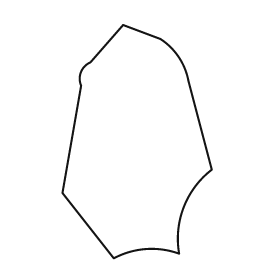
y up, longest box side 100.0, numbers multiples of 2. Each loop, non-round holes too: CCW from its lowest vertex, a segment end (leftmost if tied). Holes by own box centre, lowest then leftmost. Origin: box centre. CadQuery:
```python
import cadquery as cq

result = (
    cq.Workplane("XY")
    .moveTo(-10.0, -50.0)
    .threePointArc((4.0, -46.0), (18.0, -48.0))
    .threePointArc((20.0, -28.0), (32.0, -12.0))
    .lineTo(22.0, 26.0)
    .threePointArc((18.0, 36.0), (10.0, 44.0))
    .lineTo(-6.0, 50.0)
    .lineTo(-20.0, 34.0)
    .threePointArc((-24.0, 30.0), (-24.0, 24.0))
    .lineTo(-32.0, -22.0)
    .close()
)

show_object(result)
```